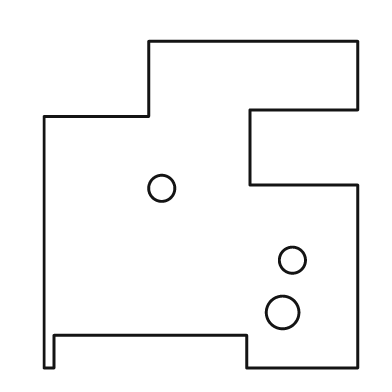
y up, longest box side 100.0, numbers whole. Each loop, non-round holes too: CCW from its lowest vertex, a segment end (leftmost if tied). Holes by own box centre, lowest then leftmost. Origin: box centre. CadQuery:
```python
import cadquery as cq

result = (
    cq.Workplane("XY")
    .moveTo(-48.0, -50.0)
    .lineTo(-45.0, -50.0)
    .lineTo(-45.0, -40.0)
    .lineTo(14.0, -40.0)
    .lineTo(14.0, -50.0)
    .lineTo(48.0, -50.0)
    .lineTo(48.0, 6.0)
    .lineTo(15.0, 6.0)
    .lineTo(15.0, 29.0)
    .lineTo(48.0, 29.0)
    .lineTo(48.0, 50.0)
    .lineTo(-16.0, 50.0)
    .lineTo(-16.0, 27.0)
    .lineTo(-48.0, 27.0)
    .close()
    .moveTo(25.0, -33.0)
    .circle(5.0)
    .moveTo(28.0, -17.0)
    .circle(4.0)
    .moveTo(-12.0, 5.0)
    .circle(4.0)
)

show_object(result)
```